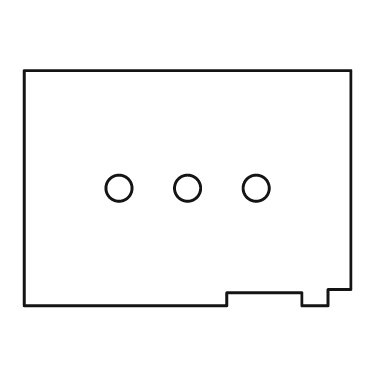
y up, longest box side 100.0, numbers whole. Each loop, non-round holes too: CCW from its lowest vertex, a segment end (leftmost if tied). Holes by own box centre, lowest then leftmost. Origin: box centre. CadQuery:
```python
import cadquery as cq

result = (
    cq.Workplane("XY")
    .moveTo(-50.0, -36.0)
    .lineTo(12.0, -36.0)
    .lineTo(12.0, -32.0)
    .lineTo(35.0, -32.0)
    .lineTo(35.0, -36.0)
    .lineTo(43.0, -36.0)
    .lineTo(43.0, -31.0)
    .lineTo(50.0, -31.0)
    .lineTo(50.0, 36.0)
    .lineTo(-50.0, 36.0)
    .close()
    .moveTo(-21.0, 0.0)
    .circle(4.0)
    .moveTo(0.0, 0.0)
    .circle(4.0)
    .moveTo(21.0, 0.0)
    .circle(4.0)
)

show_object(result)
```